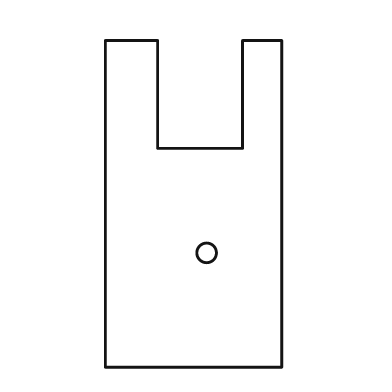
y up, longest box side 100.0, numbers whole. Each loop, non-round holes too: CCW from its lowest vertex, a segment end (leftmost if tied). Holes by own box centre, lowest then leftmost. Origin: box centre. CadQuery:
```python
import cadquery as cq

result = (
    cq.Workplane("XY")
    .moveTo(-27.0, -50.0)
    .lineTo(27.0, -50.0)
    .lineTo(27.0, 50.0)
    .lineTo(15.0, 50.0)
    .lineTo(15.0, 17.0)
    .lineTo(-11.0, 17.0)
    .lineTo(-11.0, 50.0)
    .lineTo(-27.0, 50.0)
    .close()
    .moveTo(4.0, -15.0)
    .circle(3.0)
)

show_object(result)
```